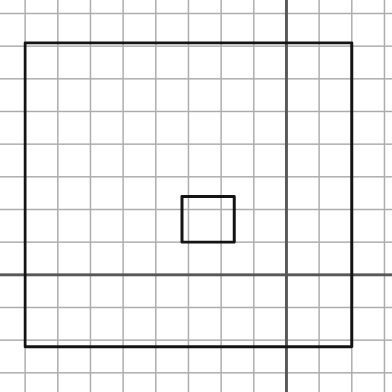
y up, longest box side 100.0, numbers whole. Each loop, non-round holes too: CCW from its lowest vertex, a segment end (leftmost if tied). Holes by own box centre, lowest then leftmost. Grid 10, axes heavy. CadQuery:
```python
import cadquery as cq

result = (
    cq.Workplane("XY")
    .moveTo(-80.0, -22.0)
    .lineTo(20.0, -22.0)
    .lineTo(20.0, 71.0)
    .lineTo(-80.0, 71.0)
    .close()
    .moveTo(-32.0, 10.0)
    .lineTo(-16.0, 10.0)
    .lineTo(-16.0, 24.0)
    .lineTo(-32.0, 24.0)
    .close()
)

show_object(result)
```